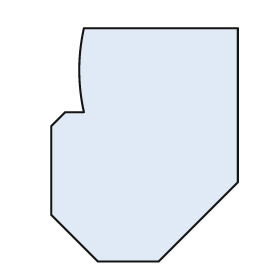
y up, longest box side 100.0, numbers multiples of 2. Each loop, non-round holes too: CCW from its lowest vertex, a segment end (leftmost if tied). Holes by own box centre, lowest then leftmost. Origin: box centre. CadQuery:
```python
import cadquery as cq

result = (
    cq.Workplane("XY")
    .moveTo(-20.0, -50.0)
    .lineTo(6.0, -50.0)
    .lineTo(40.0, -16.0)
    .lineTo(40.0, 50.0)
    .lineTo(-26.0, 50.0)
    .threePointArc((-28.0, 32.0), (-26.0, 14.0))
    .lineTo(-34.0, 14.0)
    .lineTo(-40.0, 8.0)
    .lineTo(-40.0, -30.0)
    .close()
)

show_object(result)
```